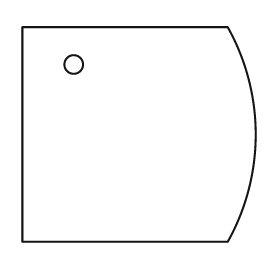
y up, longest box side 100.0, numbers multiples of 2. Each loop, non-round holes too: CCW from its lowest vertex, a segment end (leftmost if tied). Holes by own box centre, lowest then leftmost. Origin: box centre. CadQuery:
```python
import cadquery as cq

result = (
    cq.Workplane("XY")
    .moveTo(-50.0, -46.0)
    .lineTo(38.0, -46.0)
    .threePointArc((50.0, 0.0), (38.0, 46.0))
    .lineTo(-50.0, 46.0)
    .close()
    .moveTo(-28.0, 30.0)
    .circle(4.0)
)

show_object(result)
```